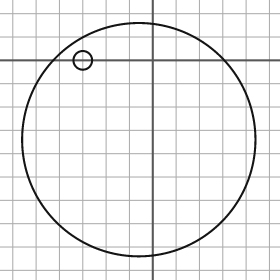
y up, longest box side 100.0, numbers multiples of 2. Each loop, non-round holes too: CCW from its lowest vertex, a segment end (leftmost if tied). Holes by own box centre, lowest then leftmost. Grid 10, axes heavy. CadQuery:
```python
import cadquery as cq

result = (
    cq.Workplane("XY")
    .moveTo(-6.0, -34.0)
    .circle(50.0)
    .moveTo(-30.0, 0.0)
    .circle(4.0)
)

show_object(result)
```